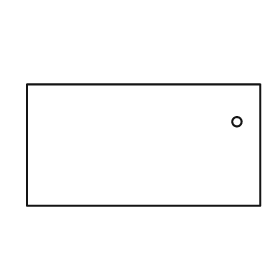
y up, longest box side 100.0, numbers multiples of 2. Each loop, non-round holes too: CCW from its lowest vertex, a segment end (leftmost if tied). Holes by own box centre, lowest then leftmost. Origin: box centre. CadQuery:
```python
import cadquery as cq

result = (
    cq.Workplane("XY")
    .moveTo(-50.0, -26.0)
    .lineTo(50.0, -26.0)
    .lineTo(50.0, 26.0)
    .lineTo(-50.0, 26.0)
    .close()
    .moveTo(40.0, 10.0)
    .circle(2.0)
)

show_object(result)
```